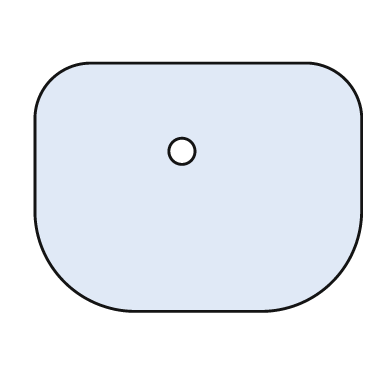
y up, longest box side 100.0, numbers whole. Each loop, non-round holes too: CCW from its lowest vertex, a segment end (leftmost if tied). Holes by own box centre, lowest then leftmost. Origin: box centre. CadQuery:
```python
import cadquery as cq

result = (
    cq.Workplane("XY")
    .moveTo(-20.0, -38.0)
    .lineTo(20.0, -38.0)
    .threePointArc((41.0, -29.0), (50.0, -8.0))
    .lineTo(50.0, 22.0)
    .threePointArc((45.0, 33.0), (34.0, 38.0))
    .lineTo(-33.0, 38.0)
    .threePointArc((-45.0, 33.0), (-50.0, 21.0))
    .lineTo(-50.0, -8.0)
    .threePointArc((-41.0, -29.0), (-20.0, -38.0))
    .close()
    .moveTo(-5.0, 11.0)
    .circle(4.0)
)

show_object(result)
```